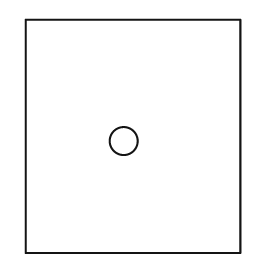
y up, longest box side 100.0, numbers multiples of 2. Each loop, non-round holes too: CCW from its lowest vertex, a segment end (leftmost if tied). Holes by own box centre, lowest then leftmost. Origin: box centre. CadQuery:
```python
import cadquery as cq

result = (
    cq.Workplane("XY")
    .moveTo(-46.0, -50.0)
    .lineTo(46.0, -50.0)
    .lineTo(46.0, 50.0)
    .lineTo(-46.0, 50.0)
    .close()
    .moveTo(-4.0, -2.0)
    .circle(6.0)
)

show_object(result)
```